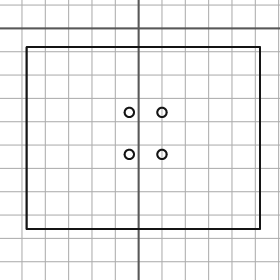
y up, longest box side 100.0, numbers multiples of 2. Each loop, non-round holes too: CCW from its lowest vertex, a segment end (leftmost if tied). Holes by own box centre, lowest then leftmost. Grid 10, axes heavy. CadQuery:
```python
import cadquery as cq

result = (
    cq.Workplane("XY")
    .moveTo(-48.0, -86.0)
    .lineTo(52.0, -86.0)
    .lineTo(52.0, -8.0)
    .lineTo(-48.0, -8.0)
    .close()
    .moveTo(-4.0, -54.0)
    .circle(2.0)
    .moveTo(10.0, -54.0)
    .circle(2.0)
    .moveTo(-4.0, -36.0)
    .circle(2.0)
    .moveTo(10.0, -36.0)
    .circle(2.0)
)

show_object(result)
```